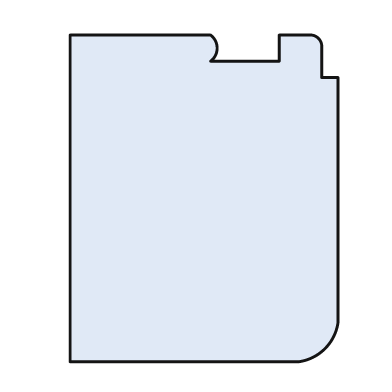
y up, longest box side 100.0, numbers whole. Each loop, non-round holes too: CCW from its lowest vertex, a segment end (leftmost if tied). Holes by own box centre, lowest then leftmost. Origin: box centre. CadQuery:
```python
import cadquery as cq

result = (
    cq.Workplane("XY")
    .moveTo(-41.0, -50.0)
    .lineTo(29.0, -50.0)
    .threePointArc((37.0, -46.0), (41.0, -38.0))
    .lineTo(41.0, 37.0)
    .lineTo(36.0, 37.0)
    .lineTo(36.0, 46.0)
    .threePointArc((35.0, 49.0), (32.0, 50.0))
    .lineTo(23.0, 50.0)
    .lineTo(23.0, 42.0)
    .lineTo(2.0, 42.0)
    .threePointArc((4.0, 46.0), (2.0, 50.0))
    .lineTo(-41.0, 50.0)
    .close()
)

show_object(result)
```